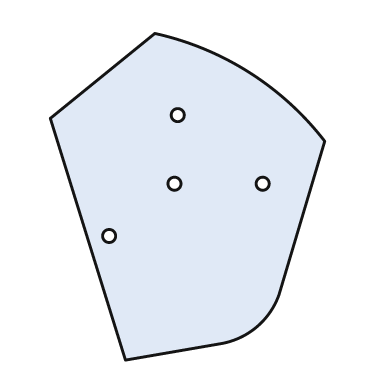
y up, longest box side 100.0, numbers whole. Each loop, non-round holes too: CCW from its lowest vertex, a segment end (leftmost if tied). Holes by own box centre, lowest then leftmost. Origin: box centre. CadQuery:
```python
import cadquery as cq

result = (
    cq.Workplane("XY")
    .moveTo(-19.0, -50.0)
    .lineTo(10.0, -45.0)
    .threePointArc((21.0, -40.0), (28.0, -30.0))
    .lineTo(42.0, 17.0)
    .threePointArc((19.0, 38.0), (-10.0, 50.0))
    .lineTo(-42.0, 24.0)
    .close()
    .moveTo(-24.0, -12.0)
    .circle(2.0)
    .moveTo(-4.0, 4.0)
    .circle(2.0)
    .moveTo(23.0, 4.0)
    .circle(2.0)
    .moveTo(-3.0, 25.0)
    .circle(2.0)
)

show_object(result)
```